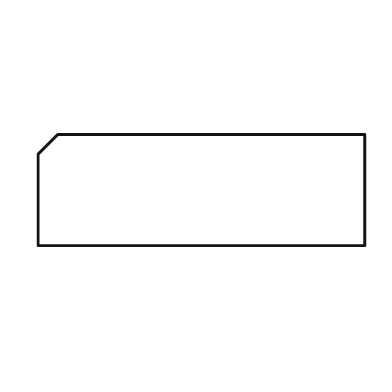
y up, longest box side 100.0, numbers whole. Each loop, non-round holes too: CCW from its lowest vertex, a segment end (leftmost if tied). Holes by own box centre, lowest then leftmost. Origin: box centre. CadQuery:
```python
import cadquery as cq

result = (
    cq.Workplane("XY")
    .moveTo(-50.0, -17.0)
    .lineTo(50.0, -17.0)
    .lineTo(50.0, 17.0)
    .lineTo(-44.0, 17.0)
    .lineTo(-50.0, 11.0)
    .close()
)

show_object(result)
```